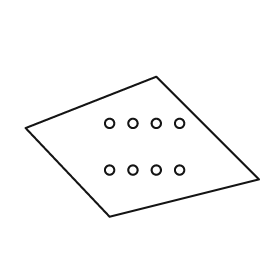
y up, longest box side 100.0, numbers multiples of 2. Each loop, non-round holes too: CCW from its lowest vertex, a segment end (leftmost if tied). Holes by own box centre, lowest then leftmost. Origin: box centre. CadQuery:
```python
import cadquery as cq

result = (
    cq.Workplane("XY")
    .moveTo(-14.0, -30.0)
    .lineTo(50.0, -14.0)
    .lineTo(6.0, 30.0)
    .lineTo(-50.0, 8.0)
    .close()
    .moveTo(-14.0, -10.0)
    .circle(2.0)
    .moveTo(-4.0, -10.0)
    .circle(2.0)
    .moveTo(6.0, -10.0)
    .circle(2.0)
    .moveTo(16.0, -10.0)
    .circle(2.0)
    .moveTo(-14.0, 10.0)
    .circle(2.0)
    .moveTo(-4.0, 10.0)
    .circle(2.0)
    .moveTo(6.0, 10.0)
    .circle(2.0)
    .moveTo(16.0, 10.0)
    .circle(2.0)
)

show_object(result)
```